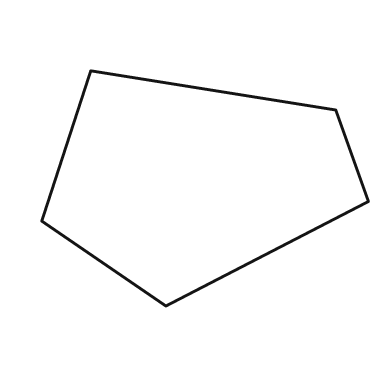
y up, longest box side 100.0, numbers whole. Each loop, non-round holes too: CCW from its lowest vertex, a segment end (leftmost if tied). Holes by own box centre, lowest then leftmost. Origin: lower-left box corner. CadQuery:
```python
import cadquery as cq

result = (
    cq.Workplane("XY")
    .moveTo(38.0, 0.0)
    .lineTo(100.0, 32.0)
    .lineTo(90.0, 60.0)
    .lineTo(15.0, 72.0)
    .lineTo(0.0, 26.0)
    .close()
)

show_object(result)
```